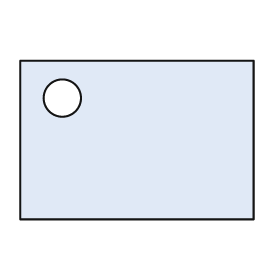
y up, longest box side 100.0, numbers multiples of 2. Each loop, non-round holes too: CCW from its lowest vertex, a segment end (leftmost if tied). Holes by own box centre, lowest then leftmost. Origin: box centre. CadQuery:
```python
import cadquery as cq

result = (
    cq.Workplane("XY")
    .moveTo(-50.0, -34.0)
    .lineTo(50.0, -34.0)
    .lineTo(50.0, 34.0)
    .lineTo(-50.0, 34.0)
    .close()
    .moveTo(-32.0, 18.0)
    .circle(8.0)
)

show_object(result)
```